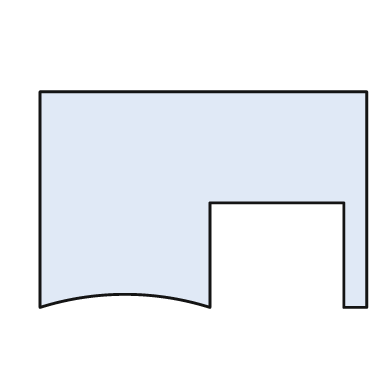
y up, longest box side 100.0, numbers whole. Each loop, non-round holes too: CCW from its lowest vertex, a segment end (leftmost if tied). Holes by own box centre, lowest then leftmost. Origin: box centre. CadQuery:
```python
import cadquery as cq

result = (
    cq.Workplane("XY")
    .moveTo(-50.0, -33.0)
    .threePointArc((-24.0, -29.0), (2.0, -33.0))
    .lineTo(2.0, -1.0)
    .lineTo(43.0, -1.0)
    .lineTo(43.0, -33.0)
    .lineTo(50.0, -33.0)
    .lineTo(50.0, 33.0)
    .lineTo(-50.0, 33.0)
    .close()
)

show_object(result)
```